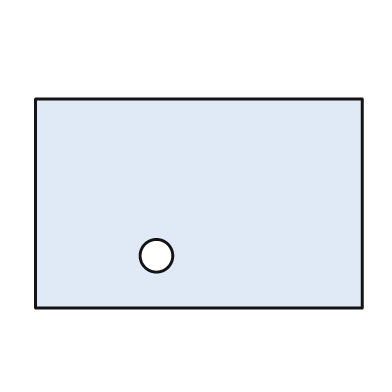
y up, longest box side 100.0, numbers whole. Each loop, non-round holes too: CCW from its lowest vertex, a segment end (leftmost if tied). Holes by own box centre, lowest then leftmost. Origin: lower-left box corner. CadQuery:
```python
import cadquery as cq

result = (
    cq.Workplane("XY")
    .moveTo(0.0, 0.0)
    .lineTo(100.0, 0.0)
    .lineTo(100.0, 64.0)
    .lineTo(0.0, 64.0)
    .close()
    .moveTo(37.0, 16.0)
    .circle(5.0)
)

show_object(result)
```